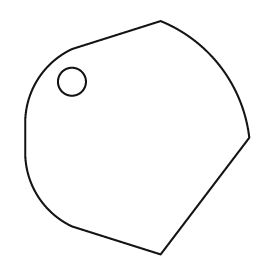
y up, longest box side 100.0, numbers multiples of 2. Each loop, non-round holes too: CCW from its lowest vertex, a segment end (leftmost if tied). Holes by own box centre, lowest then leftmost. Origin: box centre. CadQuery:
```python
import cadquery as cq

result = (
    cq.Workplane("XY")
    .moveTo(10.0, -50.0)
    .lineTo(48.0, 0.0)
    .threePointArc((36.0, 30.0), (10.0, 50.0))
    .lineTo(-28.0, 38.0)
    .threePointArc((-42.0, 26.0), (-48.0, 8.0))
    .lineTo(-48.0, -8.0)
    .threePointArc((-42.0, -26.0), (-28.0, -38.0))
    .close()
    .moveTo(-28.0, 24.0)
    .circle(6.0)
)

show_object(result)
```